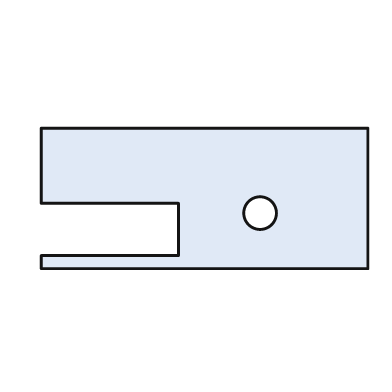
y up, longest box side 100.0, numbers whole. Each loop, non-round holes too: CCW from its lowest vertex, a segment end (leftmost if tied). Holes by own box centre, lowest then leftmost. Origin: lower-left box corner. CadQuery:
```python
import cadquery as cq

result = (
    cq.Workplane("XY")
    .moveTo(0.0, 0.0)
    .lineTo(100.0, 0.0)
    .lineTo(100.0, 43.0)
    .lineTo(0.0, 43.0)
    .lineTo(0.0, 20.0)
    .lineTo(42.0, 20.0)
    .lineTo(42.0, 4.0)
    .lineTo(0.0, 4.0)
    .close()
    .moveTo(67.0, 17.0)
    .circle(5.0)
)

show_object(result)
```